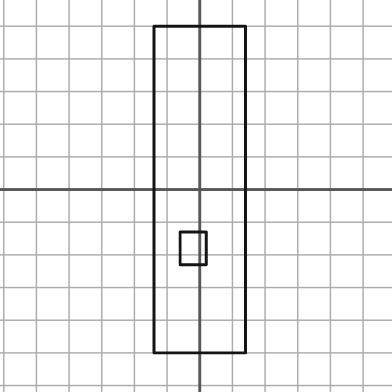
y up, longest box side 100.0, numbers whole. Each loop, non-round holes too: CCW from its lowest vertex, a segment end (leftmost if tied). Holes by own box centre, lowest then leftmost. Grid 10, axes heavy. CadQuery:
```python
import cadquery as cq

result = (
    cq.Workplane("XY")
    .moveTo(-14.0, -50.0)
    .lineTo(14.0, -50.0)
    .lineTo(14.0, 50.0)
    .lineTo(-14.0, 50.0)
    .close()
    .moveTo(-6.0, -23.0)
    .lineTo(2.0, -23.0)
    .lineTo(2.0, -13.0)
    .lineTo(-6.0, -13.0)
    .close()
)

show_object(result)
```